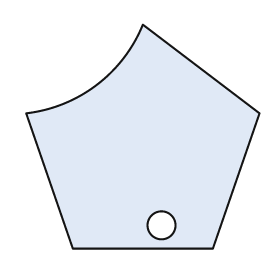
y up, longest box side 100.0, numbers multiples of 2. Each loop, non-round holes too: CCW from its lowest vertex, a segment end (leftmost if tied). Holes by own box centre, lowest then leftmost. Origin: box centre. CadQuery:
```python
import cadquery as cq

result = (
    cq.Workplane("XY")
    .moveTo(-30.0, -48.0)
    .lineTo(30.0, -48.0)
    .lineTo(50.0, 10.0)
    .lineTo(0.0, 48.0)
    .threePointArc((-20.0, 22.0), (-50.0, 10.0))
    .close()
    .moveTo(8.0, -38.0)
    .circle(6.0)
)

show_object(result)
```